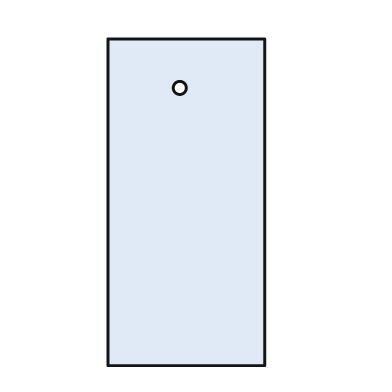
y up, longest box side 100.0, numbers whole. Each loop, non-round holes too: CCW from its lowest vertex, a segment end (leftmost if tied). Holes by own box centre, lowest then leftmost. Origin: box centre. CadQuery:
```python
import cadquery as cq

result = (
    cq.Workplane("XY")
    .moveTo(-24.0, -50.0)
    .lineTo(24.0, -50.0)
    .lineTo(24.0, 50.0)
    .lineTo(-24.0, 50.0)
    .close()
    .moveTo(-2.0, 35.0)
    .circle(2.0)
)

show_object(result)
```